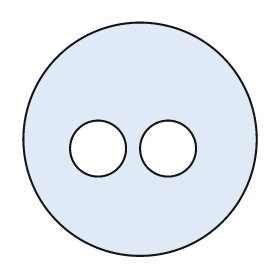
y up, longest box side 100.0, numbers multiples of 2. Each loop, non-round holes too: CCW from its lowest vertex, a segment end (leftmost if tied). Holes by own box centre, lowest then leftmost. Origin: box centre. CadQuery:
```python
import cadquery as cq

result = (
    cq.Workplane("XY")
    .moveTo(0.0, 0.0)
    .circle(50.0)
    .moveTo(-18.0, -4.0)
    .circle(12.0)
    .moveTo(12.0, -4.0)
    .circle(12.0)
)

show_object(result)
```